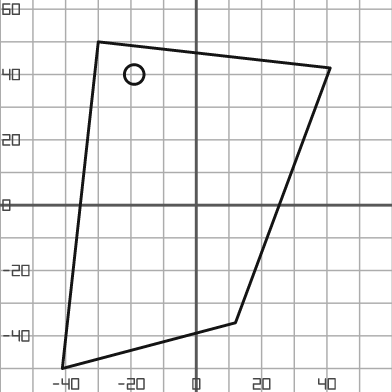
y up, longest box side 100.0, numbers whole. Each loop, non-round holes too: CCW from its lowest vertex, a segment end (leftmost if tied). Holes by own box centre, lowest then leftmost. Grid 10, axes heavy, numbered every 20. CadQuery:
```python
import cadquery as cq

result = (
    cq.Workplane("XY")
    .moveTo(-41.0, -50.0)
    .lineTo(12.0, -36.0)
    .lineTo(41.0, 42.0)
    .lineTo(-30.0, 50.0)
    .close()
    .moveTo(-19.0, 40.0)
    .circle(3.0)
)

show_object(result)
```